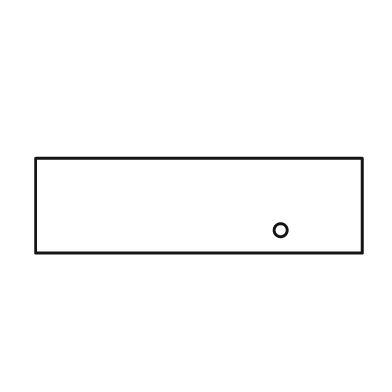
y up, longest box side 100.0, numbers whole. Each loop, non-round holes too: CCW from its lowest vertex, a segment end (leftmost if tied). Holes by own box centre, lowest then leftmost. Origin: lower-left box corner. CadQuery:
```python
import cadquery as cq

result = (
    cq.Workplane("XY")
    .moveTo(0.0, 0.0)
    .lineTo(100.0, 0.0)
    .lineTo(100.0, 29.0)
    .lineTo(0.0, 29.0)
    .close()
    .moveTo(75.0, 7.0)
    .circle(2.0)
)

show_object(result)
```